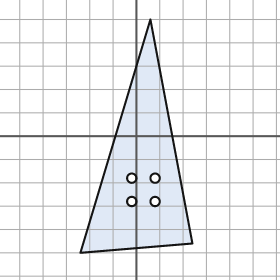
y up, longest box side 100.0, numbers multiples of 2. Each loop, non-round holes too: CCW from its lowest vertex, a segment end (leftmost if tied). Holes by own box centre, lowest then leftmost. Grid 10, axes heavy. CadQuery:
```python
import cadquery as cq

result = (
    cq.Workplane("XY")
    .moveTo(-24.0, -50.0)
    .lineTo(24.0, -46.0)
    .lineTo(6.0, 50.0)
    .close()
    .moveTo(-2.0, -28.0)
    .circle(2.0)
    .moveTo(8.0, -28.0)
    .circle(2.0)
    .moveTo(-2.0, -18.0)
    .circle(2.0)
    .moveTo(8.0, -18.0)
    .circle(2.0)
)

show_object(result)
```